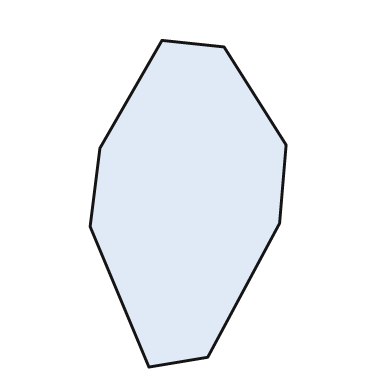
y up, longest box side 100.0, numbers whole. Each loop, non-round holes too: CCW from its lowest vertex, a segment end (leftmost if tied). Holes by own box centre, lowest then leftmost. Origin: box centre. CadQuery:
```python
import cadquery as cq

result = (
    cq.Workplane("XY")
    .moveTo(-12.0, -50.0)
    .lineTo(6.0, -47.0)
    .lineTo(28.0, -6.0)
    .lineTo(30.0, 18.0)
    .lineTo(11.0, 48.0)
    .lineTo(-8.0, 50.0)
    .lineTo(-27.0, 17.0)
    .lineTo(-30.0, -7.0)
    .close()
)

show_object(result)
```